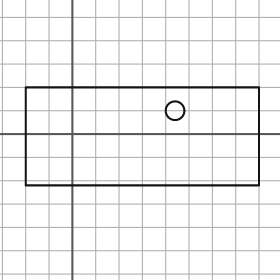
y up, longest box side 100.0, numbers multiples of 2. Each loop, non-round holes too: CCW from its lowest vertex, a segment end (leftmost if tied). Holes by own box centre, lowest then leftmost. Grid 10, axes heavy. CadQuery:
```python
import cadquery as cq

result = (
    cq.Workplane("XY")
    .moveTo(-20.0, -22.0)
    .lineTo(80.0, -22.0)
    .lineTo(80.0, 20.0)
    .lineTo(-20.0, 20.0)
    .close()
    .moveTo(44.0, 10.0)
    .circle(4.0)
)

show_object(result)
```